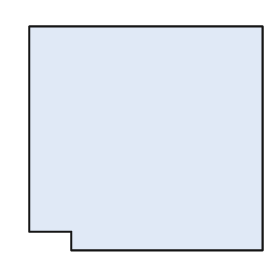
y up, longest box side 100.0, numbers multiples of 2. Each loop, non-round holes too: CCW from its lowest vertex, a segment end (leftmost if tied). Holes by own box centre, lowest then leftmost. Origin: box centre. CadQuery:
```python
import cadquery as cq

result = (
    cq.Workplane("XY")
    .moveTo(-32.0, -48.0)
    .lineTo(50.0, -48.0)
    .lineTo(50.0, 48.0)
    .lineTo(-50.0, 48.0)
    .lineTo(-50.0, -40.0)
    .lineTo(-32.0, -40.0)
    .close()
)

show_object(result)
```